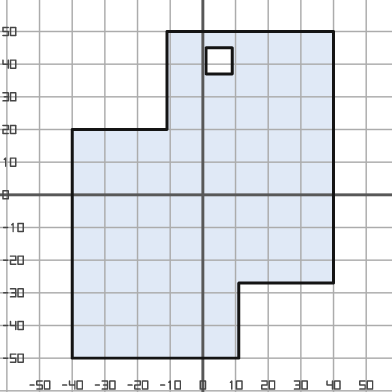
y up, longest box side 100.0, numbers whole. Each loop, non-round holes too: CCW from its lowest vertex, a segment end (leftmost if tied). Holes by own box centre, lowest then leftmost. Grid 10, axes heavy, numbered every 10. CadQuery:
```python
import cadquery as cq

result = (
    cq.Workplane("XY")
    .moveTo(-40.0, -50.0)
    .lineTo(11.0, -50.0)
    .lineTo(11.0, -27.0)
    .lineTo(40.0, -27.0)
    .lineTo(40.0, 50.0)
    .lineTo(-11.0, 50.0)
    .lineTo(-11.0, 20.0)
    .lineTo(-40.0, 20.0)
    .close()
    .moveTo(1.0, 37.0)
    .lineTo(9.0, 37.0)
    .lineTo(9.0, 45.0)
    .lineTo(1.0, 45.0)
    .close()
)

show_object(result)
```